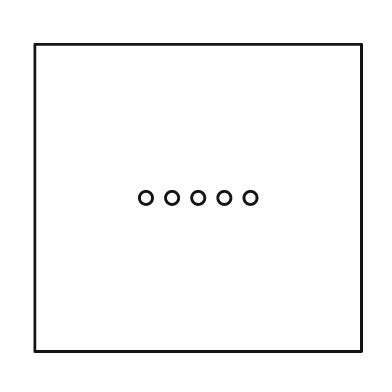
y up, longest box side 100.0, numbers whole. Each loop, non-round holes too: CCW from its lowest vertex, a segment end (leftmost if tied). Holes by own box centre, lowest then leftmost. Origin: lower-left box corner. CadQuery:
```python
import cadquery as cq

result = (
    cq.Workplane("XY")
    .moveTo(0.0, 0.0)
    .lineTo(100.0, 0.0)
    .lineTo(100.0, 94.0)
    .lineTo(0.0, 94.0)
    .close()
    .moveTo(34.0, 47.0)
    .circle(2.0)
    .moveTo(42.0, 47.0)
    .circle(2.0)
    .moveTo(50.0, 47.0)
    .circle(2.0)
    .moveTo(58.0, 47.0)
    .circle(2.0)
    .moveTo(66.0, 47.0)
    .circle(2.0)
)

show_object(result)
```